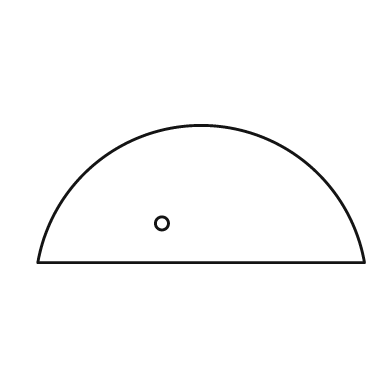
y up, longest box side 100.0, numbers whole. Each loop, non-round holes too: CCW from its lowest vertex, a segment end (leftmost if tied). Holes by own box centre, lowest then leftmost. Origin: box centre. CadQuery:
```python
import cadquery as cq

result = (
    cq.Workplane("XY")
    .moveTo(-50.0, -21.0)
    .lineTo(50.0, -21.0)
    .threePointArc((0.0, 21.0), (-50.0, -21.0))
    .close()
    .moveTo(-12.0, -9.0)
    .circle(2.0)
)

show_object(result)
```